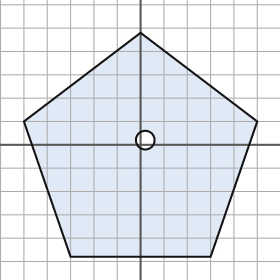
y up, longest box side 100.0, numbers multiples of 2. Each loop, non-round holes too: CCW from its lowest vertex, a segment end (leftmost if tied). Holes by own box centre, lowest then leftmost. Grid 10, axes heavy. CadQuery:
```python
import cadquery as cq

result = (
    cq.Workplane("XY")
    .moveTo(-30.0, -48.0)
    .lineTo(30.0, -48.0)
    .lineTo(50.0, 10.0)
    .lineTo(0.0, 48.0)
    .lineTo(-50.0, 10.0)
    .close()
    .moveTo(2.0, 2.0)
    .circle(4.0)
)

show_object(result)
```